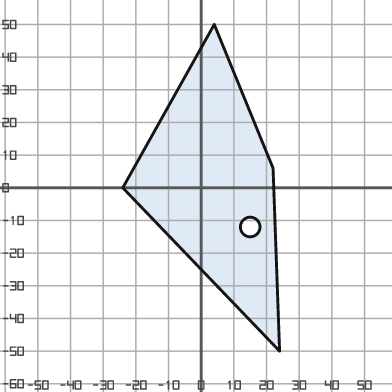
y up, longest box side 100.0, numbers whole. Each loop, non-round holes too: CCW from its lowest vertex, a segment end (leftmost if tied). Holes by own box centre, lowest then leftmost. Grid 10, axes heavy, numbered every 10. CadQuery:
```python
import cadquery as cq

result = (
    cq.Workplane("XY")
    .moveTo(24.0, -50.0)
    .lineTo(22.0, 6.0)
    .lineTo(4.0, 50.0)
    .lineTo(-24.0, 0.0)
    .close()
    .moveTo(15.0, -12.0)
    .circle(3.0)
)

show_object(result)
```